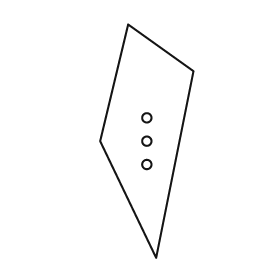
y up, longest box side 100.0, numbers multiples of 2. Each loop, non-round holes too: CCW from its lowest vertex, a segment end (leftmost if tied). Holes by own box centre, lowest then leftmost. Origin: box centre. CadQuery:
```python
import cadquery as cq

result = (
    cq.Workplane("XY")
    .moveTo(4.0, -50.0)
    .lineTo(20.0, 30.0)
    .lineTo(-8.0, 50.0)
    .lineTo(-20.0, 0.0)
    .close()
    .moveTo(0.0, -10.0)
    .circle(2.0)
    .moveTo(0.0, 0.0)
    .circle(2.0)
    .moveTo(0.0, 10.0)
    .circle(2.0)
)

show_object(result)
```